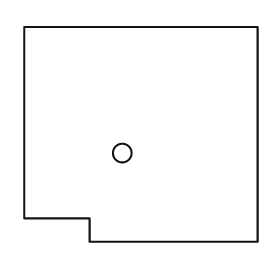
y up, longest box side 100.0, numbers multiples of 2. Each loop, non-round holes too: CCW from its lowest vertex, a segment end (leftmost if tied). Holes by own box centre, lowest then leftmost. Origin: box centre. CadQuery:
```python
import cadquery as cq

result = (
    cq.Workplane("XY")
    .moveTo(-22.0, -46.0)
    .lineTo(50.0, -46.0)
    .lineTo(50.0, 46.0)
    .lineTo(-50.0, 46.0)
    .lineTo(-50.0, -36.0)
    .lineTo(-22.0, -36.0)
    .close()
    .moveTo(-8.0, -8.0)
    .circle(4.0)
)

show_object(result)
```